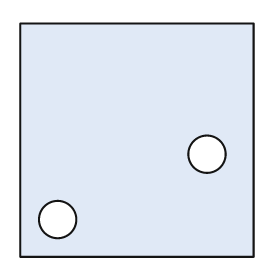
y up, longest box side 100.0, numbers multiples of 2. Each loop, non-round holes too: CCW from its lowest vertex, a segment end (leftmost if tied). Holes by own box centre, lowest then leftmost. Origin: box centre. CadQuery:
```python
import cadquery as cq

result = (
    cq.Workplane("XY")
    .moveTo(-50.0, -50.0)
    .lineTo(50.0, -50.0)
    .lineTo(50.0, 50.0)
    .lineTo(-50.0, 50.0)
    .close()
    .moveTo(-34.0, -34.0)
    .circle(8.0)
    .moveTo(30.0, -6.0)
    .circle(8.0)
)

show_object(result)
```